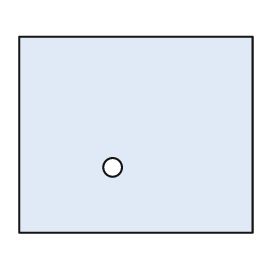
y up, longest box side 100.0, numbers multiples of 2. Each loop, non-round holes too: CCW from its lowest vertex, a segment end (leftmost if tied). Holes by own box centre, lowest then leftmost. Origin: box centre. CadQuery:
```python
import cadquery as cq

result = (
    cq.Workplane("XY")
    .moveTo(-50.0, -42.0)
    .lineTo(50.0, -42.0)
    .lineTo(50.0, 42.0)
    .lineTo(-50.0, 42.0)
    .close()
    .moveTo(-10.0, -14.0)
    .circle(4.0)
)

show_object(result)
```